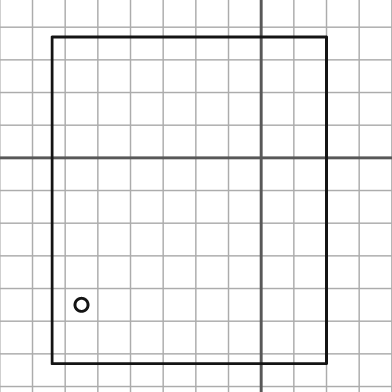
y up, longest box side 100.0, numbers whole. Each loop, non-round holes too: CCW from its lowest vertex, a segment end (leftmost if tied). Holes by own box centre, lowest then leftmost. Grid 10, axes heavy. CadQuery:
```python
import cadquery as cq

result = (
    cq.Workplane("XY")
    .moveTo(-64.0, -63.0)
    .lineTo(20.0, -63.0)
    .lineTo(20.0, 37.0)
    .lineTo(-64.0, 37.0)
    .close()
    .moveTo(-55.0, -45.0)
    .circle(2.0)
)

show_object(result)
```